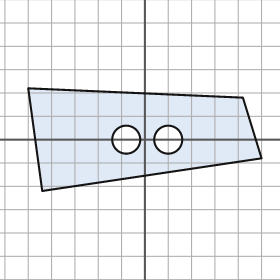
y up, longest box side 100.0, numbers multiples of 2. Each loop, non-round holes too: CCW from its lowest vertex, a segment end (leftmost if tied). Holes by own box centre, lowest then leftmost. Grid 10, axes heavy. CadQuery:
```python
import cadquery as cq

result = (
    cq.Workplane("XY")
    .moveTo(-44.0, -22.0)
    .lineTo(50.0, -8.0)
    .lineTo(42.0, 18.0)
    .lineTo(-50.0, 22.0)
    .close()
    .moveTo(-8.0, 0.0)
    .circle(6.0)
    .moveTo(10.0, 0.0)
    .circle(6.0)
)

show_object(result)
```